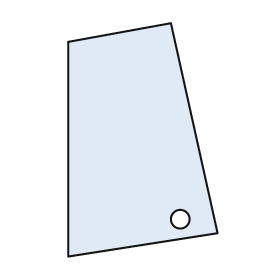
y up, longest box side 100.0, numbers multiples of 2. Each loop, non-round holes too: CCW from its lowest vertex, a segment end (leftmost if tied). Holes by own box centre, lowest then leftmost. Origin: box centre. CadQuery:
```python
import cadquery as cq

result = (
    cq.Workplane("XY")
    .moveTo(-32.0, -50.0)
    .lineTo(32.0, -40.0)
    .lineTo(12.0, 50.0)
    .lineTo(-32.0, 42.0)
    .close()
    .moveTo(16.0, -34.0)
    .circle(4.0)
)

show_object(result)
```